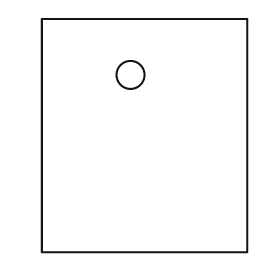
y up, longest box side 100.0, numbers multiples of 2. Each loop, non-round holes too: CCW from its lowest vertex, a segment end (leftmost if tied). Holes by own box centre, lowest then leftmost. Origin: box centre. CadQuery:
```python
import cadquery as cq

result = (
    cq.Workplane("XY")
    .moveTo(-44.0, -50.0)
    .lineTo(44.0, -50.0)
    .lineTo(44.0, 50.0)
    .lineTo(-44.0, 50.0)
    .close()
    .moveTo(-6.0, 26.0)
    .circle(6.0)
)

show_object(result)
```